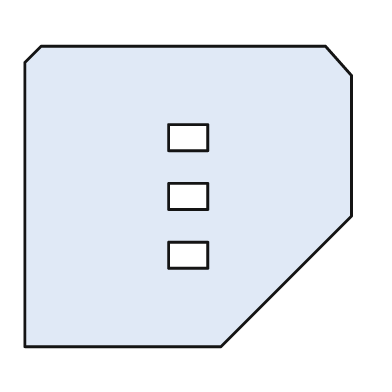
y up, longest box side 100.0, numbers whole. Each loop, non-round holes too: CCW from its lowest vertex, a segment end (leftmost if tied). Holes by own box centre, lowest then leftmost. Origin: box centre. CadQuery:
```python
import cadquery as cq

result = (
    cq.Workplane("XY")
    .moveTo(-50.0, -46.0)
    .lineTo(10.0, -46.0)
    .lineTo(50.0, -6.0)
    .lineTo(50.0, 37.0)
    .lineTo(42.0, 46.0)
    .lineTo(-45.0, 46.0)
    .lineTo(-50.0, 41.0)
    .close()
    .moveTo(-6.0, -22.0)
    .lineTo(6.0, -22.0)
    .lineTo(6.0, -14.0)
    .lineTo(-6.0, -14.0)
    .close()
    .moveTo(-6.0, -4.0)
    .lineTo(6.0, -4.0)
    .lineTo(6.0, 4.0)
    .lineTo(-6.0, 4.0)
    .close()
    .moveTo(-6.0, 14.0)
    .lineTo(6.0, 14.0)
    .lineTo(6.0, 22.0)
    .lineTo(-6.0, 22.0)
    .close()
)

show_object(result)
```